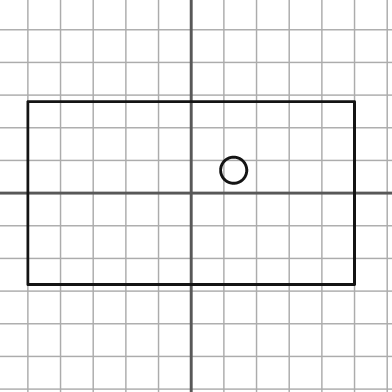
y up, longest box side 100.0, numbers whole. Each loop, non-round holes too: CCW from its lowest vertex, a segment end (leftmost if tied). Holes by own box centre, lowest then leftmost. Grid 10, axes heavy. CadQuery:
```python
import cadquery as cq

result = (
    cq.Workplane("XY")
    .moveTo(-50.0, -28.0)
    .lineTo(50.0, -28.0)
    .lineTo(50.0, 28.0)
    .lineTo(-50.0, 28.0)
    .close()
    .moveTo(13.0, 7.0)
    .circle(4.0)
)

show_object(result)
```